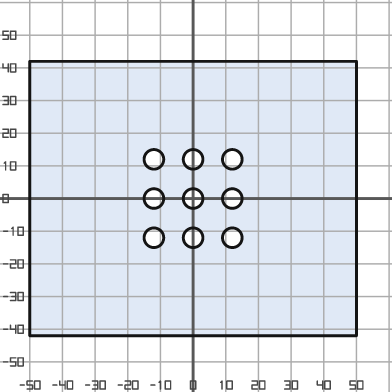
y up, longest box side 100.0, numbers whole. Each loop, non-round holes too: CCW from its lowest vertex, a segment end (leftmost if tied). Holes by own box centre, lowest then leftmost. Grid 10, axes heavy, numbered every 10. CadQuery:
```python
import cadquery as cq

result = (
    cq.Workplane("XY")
    .moveTo(-50.0, -42.0)
    .lineTo(50.0, -42.0)
    .lineTo(50.0, 42.0)
    .lineTo(-50.0, 42.0)
    .close()
    .moveTo(-12.0, -12.0)
    .circle(3.0)
    .moveTo(0.0, -12.0)
    .circle(3.0)
    .moveTo(12.0, -12.0)
    .circle(3.0)
    .moveTo(-12.0, 0.0)
    .circle(3.0)
    .moveTo(0.0, 0.0)
    .circle(3.0)
    .moveTo(12.0, 0.0)
    .circle(3.0)
    .moveTo(-12.0, 12.0)
    .circle(3.0)
    .moveTo(0.0, 12.0)
    .circle(3.0)
    .moveTo(12.0, 12.0)
    .circle(3.0)
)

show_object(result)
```